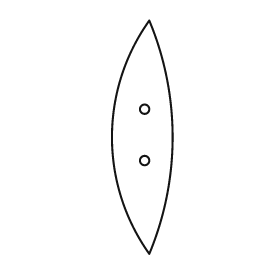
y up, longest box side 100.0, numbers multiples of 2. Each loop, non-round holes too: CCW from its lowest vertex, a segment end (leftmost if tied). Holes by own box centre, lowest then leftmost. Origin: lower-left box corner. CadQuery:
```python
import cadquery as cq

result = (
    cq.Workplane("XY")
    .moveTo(16.0, 0.0)
    .threePointArc((26.0, 50.0), (16.0, 100.0))
    .threePointArc((0.0, 50.0), (16.0, 0.0))
    .close()
    .moveTo(14.0, 40.0)
    .circle(2.0)
    .moveTo(14.0, 62.0)
    .circle(2.0)
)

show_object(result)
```